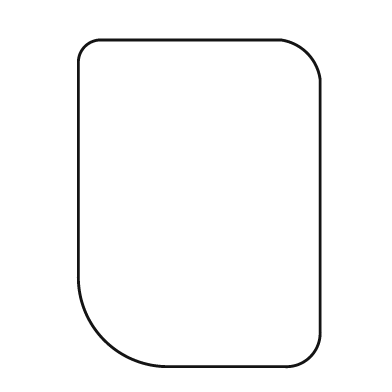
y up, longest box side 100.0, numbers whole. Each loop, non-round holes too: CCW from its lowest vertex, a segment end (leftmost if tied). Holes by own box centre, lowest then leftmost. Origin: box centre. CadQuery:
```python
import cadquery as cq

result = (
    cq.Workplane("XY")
    .moveTo(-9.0, -50.0)
    .lineTo(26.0, -50.0)
    .threePointArc((34.0, -47.0), (37.0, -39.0))
    .lineTo(37.0, 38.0)
    .threePointArc((33.0, 46.0), (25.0, 50.0))
    .lineTo(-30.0, 50.0)
    .threePointArc((-35.0, 48.0), (-37.0, 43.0))
    .lineTo(-37.0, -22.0)
    .threePointArc((-29.0, -42.0), (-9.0, -50.0))
    .close()
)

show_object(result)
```